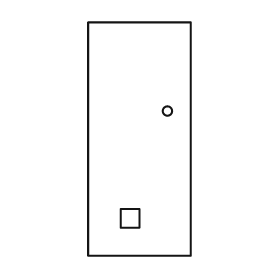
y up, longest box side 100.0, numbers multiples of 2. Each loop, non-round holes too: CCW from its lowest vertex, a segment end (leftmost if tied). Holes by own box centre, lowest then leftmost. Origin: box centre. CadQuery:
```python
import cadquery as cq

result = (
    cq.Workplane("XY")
    .moveTo(-22.0, -50.0)
    .lineTo(22.0, -50.0)
    .lineTo(22.0, 50.0)
    .lineTo(-22.0, 50.0)
    .close()
    .moveTo(-8.0, -38.0)
    .lineTo(0.0, -38.0)
    .lineTo(0.0, -30.0)
    .lineTo(-8.0, -30.0)
    .close()
    .moveTo(12.0, 12.0)
    .circle(2.0)
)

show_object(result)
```